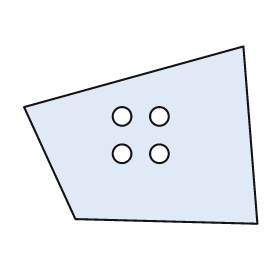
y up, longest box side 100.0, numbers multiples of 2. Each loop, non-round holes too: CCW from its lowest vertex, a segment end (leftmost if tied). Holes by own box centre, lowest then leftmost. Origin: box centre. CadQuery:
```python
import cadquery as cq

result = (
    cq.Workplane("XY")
    .moveTo(50.0, -38.0)
    .lineTo(44.0, 38.0)
    .lineTo(-50.0, 12.0)
    .lineTo(-28.0, -36.0)
    .close()
    .moveTo(-8.0, -8.0)
    .circle(4.0)
    .moveTo(8.0, -8.0)
    .circle(4.0)
    .moveTo(-8.0, 8.0)
    .circle(4.0)
    .moveTo(8.0, 8.0)
    .circle(4.0)
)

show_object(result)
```